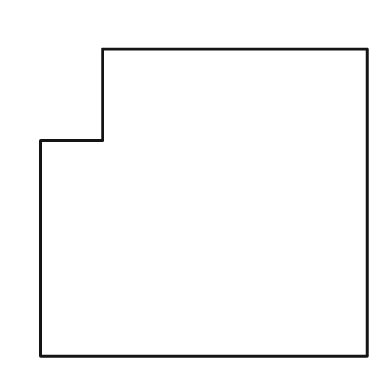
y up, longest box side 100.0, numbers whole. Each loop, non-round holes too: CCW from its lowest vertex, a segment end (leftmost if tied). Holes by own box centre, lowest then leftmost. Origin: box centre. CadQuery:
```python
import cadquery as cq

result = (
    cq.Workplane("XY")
    .moveTo(-50.0, -47.0)
    .lineTo(50.0, -47.0)
    .lineTo(50.0, 47.0)
    .lineTo(-31.0, 47.0)
    .lineTo(-31.0, 19.0)
    .lineTo(-50.0, 19.0)
    .close()
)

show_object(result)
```